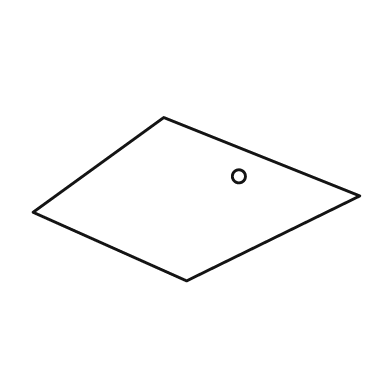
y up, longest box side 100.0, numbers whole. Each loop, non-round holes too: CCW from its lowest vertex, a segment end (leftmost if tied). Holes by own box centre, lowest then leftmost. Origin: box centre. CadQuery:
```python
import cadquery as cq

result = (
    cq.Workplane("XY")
    .moveTo(-3.0, -25.0)
    .lineTo(50.0, 1.0)
    .lineTo(-10.0, 25.0)
    .lineTo(-50.0, -4.0)
    .close()
    .moveTo(13.0, 7.0)
    .circle(2.0)
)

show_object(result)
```